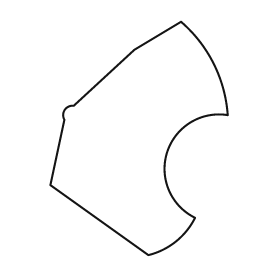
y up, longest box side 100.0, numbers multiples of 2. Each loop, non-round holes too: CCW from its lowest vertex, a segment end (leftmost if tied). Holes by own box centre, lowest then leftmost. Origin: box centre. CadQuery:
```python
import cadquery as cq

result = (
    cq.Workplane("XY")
    .moveTo(4.0, -50.0)
    .threePointArc((16.0, -44.0), (24.0, -34.0))
    .threePointArc((12.0, -6.0), (38.0, 10.0))
    .threePointArc((32.0, 32.0), (18.0, 50.0))
    .lineTo(-2.0, 38.0)
    .lineTo(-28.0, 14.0)
    .threePointArc((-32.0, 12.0), (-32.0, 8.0))
    .lineTo(-38.0, -20.0)
    .close()
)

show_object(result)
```